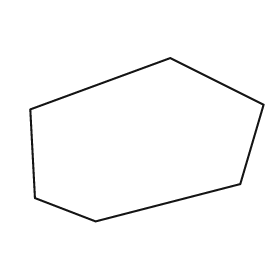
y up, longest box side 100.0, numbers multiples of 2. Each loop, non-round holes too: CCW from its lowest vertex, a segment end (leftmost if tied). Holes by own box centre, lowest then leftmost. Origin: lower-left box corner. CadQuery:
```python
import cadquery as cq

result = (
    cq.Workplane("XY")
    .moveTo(28.0, 0.0)
    .lineTo(90.0, 16.0)
    .lineTo(100.0, 50.0)
    .lineTo(60.0, 70.0)
    .lineTo(0.0, 48.0)
    .lineTo(2.0, 10.0)
    .close()
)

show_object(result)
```